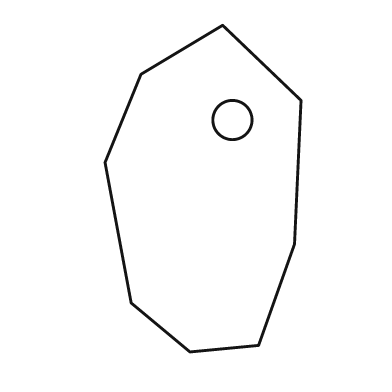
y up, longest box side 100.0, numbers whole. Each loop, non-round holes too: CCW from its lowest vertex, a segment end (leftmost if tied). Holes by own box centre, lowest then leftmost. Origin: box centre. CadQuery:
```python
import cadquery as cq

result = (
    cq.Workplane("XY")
    .moveTo(-4.0, -50.0)
    .lineTo(17.0, -48.0)
    .lineTo(28.0, -17.0)
    .lineTo(30.0, 27.0)
    .lineTo(6.0, 50.0)
    .lineTo(-19.0, 35.0)
    .lineTo(-30.0, 8.0)
    .lineTo(-22.0, -35.0)
    .close()
    .moveTo(9.0, 21.0)
    .circle(6.0)
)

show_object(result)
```